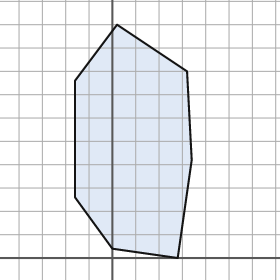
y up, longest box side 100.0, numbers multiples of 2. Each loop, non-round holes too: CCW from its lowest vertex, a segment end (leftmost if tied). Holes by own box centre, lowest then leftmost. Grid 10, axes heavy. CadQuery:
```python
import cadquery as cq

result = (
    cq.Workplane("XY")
    .moveTo(28.0, 0.0)
    .lineTo(34.0, 42.0)
    .lineTo(32.0, 80.0)
    .lineTo(2.0, 100.0)
    .lineTo(-16.0, 76.0)
    .lineTo(-16.0, 26.0)
    .lineTo(0.0, 4.0)
    .close()
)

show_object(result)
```